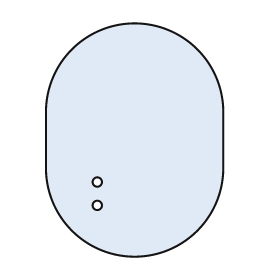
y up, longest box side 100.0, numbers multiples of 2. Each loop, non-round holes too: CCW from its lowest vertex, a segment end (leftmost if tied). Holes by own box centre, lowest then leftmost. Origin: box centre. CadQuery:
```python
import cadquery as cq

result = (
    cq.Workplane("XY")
    .moveTo(-38.0, -12.0)
    .threePointArc((0.0, -50.0), (38.0, -12.0))
    .lineTo(38.0, 12.0)
    .threePointArc((0.0, 50.0), (-38.0, 12.0))
    .close()
    .moveTo(-16.0, -28.0)
    .circle(2.0)
    .moveTo(-16.0, -18.0)
    .circle(2.0)
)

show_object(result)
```